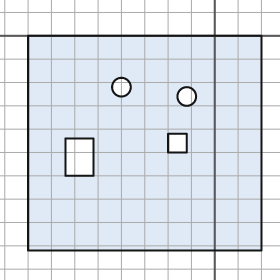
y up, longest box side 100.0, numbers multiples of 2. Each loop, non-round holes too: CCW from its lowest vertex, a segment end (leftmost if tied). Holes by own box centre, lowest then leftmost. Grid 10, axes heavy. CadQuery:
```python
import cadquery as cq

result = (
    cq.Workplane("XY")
    .moveTo(-80.0, -92.0)
    .lineTo(20.0, -92.0)
    .lineTo(20.0, 0.0)
    .lineTo(-80.0, 0.0)
    .close()
    .moveTo(-64.0, -60.0)
    .lineTo(-52.0, -60.0)
    .lineTo(-52.0, -44.0)
    .lineTo(-64.0, -44.0)
    .close()
    .moveTo(-20.0, -50.0)
    .lineTo(-12.0, -50.0)
    .lineTo(-12.0, -42.0)
    .lineTo(-20.0, -42.0)
    .close()
    .moveTo(-12.0, -26.0)
    .circle(4.0)
    .moveTo(-40.0, -22.0)
    .circle(4.0)
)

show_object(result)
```